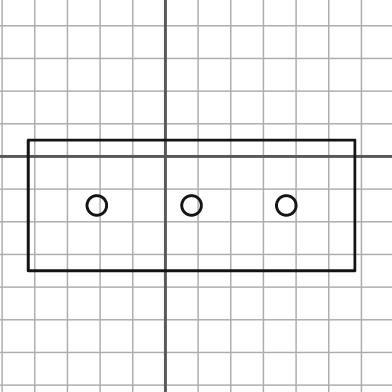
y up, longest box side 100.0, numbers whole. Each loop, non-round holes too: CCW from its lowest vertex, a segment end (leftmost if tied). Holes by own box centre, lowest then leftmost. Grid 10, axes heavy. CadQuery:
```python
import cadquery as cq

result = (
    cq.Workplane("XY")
    .moveTo(-42.0, -35.0)
    .lineTo(58.0, -35.0)
    .lineTo(58.0, 5.0)
    .lineTo(-42.0, 5.0)
    .close()
    .moveTo(-21.0, -15.0)
    .circle(3.0)
    .moveTo(8.0, -15.0)
    .circle(3.0)
    .moveTo(37.0, -15.0)
    .circle(3.0)
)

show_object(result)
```